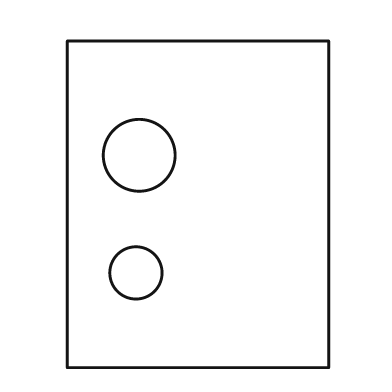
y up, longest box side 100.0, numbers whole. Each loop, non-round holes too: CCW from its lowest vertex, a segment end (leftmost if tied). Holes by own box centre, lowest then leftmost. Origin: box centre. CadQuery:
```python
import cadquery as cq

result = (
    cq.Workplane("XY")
    .moveTo(-40.0, -50.0)
    .lineTo(40.0, -50.0)
    .lineTo(40.0, 50.0)
    .lineTo(-40.0, 50.0)
    .close()
    .moveTo(-19.0, -21.0)
    .circle(8.0)
    .moveTo(-18.0, 15.0)
    .circle(11.0)
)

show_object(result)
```